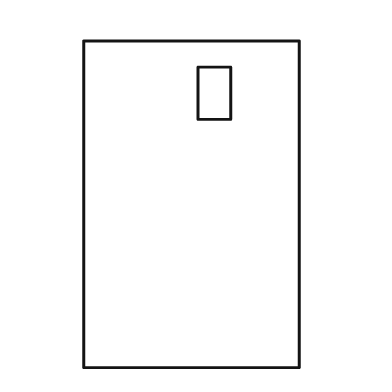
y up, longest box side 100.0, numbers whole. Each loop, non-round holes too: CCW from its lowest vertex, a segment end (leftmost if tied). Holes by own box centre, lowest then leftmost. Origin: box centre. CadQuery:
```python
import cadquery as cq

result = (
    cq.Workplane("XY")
    .moveTo(-33.0, -50.0)
    .lineTo(33.0, -50.0)
    .lineTo(33.0, 50.0)
    .lineTo(-33.0, 50.0)
    .close()
    .moveTo(2.0, 26.0)
    .lineTo(12.0, 26.0)
    .lineTo(12.0, 42.0)
    .lineTo(2.0, 42.0)
    .close()
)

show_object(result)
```